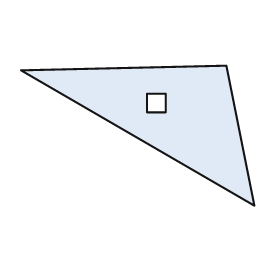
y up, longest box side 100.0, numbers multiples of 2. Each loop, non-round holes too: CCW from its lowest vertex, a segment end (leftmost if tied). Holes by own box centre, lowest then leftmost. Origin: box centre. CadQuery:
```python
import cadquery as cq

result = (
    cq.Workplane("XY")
    .moveTo(50.0, -30.0)
    .lineTo(38.0, 30.0)
    .lineTo(-50.0, 28.0)
    .close()
    .moveTo(4.0, 10.0)
    .lineTo(12.0, 10.0)
    .lineTo(12.0, 18.0)
    .lineTo(4.0, 18.0)
    .close()
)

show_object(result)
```